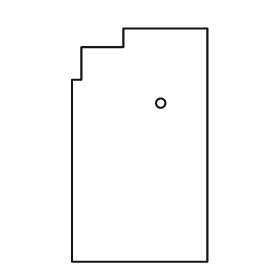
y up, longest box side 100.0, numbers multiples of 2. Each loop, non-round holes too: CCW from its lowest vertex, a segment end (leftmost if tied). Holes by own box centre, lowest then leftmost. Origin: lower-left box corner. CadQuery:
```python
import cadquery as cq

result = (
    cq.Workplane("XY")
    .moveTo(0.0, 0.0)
    .lineTo(58.0, 0.0)
    .lineTo(58.0, 100.0)
    .lineTo(22.0, 100.0)
    .lineTo(22.0, 92.0)
    .lineTo(4.0, 92.0)
    .lineTo(4.0, 78.0)
    .lineTo(0.0, 78.0)
    .close()
    .moveTo(38.0, 68.0)
    .circle(2.0)
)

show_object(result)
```